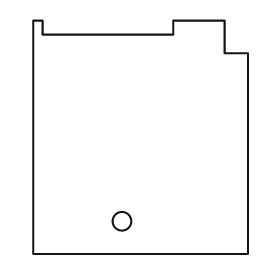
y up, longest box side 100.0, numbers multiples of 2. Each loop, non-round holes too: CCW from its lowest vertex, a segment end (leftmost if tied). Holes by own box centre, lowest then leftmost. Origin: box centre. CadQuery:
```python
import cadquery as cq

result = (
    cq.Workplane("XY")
    .moveTo(-46.0, -50.0)
    .lineTo(46.0, -50.0)
    .lineTo(46.0, 36.0)
    .lineTo(36.0, 36.0)
    .lineTo(36.0, 50.0)
    .lineTo(14.0, 50.0)
    .lineTo(14.0, 44.0)
    .lineTo(-42.0, 44.0)
    .lineTo(-42.0, 50.0)
    .lineTo(-46.0, 50.0)
    .close()
    .moveTo(-8.0, -36.0)
    .circle(4.0)
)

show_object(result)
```